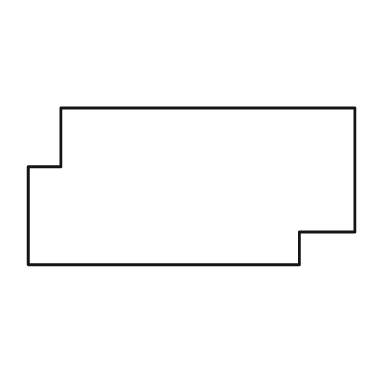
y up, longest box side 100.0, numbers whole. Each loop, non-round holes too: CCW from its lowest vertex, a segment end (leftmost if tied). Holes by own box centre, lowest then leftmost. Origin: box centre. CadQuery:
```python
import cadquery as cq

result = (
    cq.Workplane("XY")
    .moveTo(-50.0, -24.0)
    .lineTo(33.0, -24.0)
    .lineTo(33.0, -14.0)
    .lineTo(50.0, -14.0)
    .lineTo(50.0, 24.0)
    .lineTo(-40.0, 24.0)
    .lineTo(-40.0, 6.0)
    .lineTo(-50.0, 6.0)
    .close()
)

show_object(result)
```